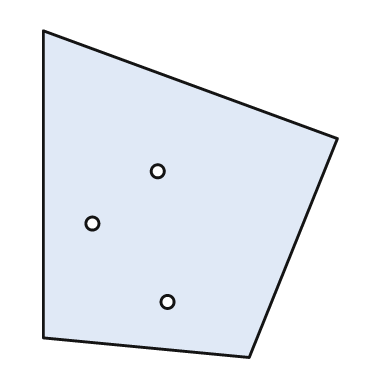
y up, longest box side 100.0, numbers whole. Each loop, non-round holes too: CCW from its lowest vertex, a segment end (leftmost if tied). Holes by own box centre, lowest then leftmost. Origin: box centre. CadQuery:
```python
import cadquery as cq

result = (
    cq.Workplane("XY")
    .moveTo(18.0, -50.0)
    .lineTo(45.0, 17.0)
    .lineTo(-45.0, 50.0)
    .lineTo(-45.0, -44.0)
    .close()
    .moveTo(-7.0, -33.0)
    .circle(2.0)
    .moveTo(-30.0, -9.0)
    .circle(2.0)
    .moveTo(-10.0, 7.0)
    .circle(2.0)
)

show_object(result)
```